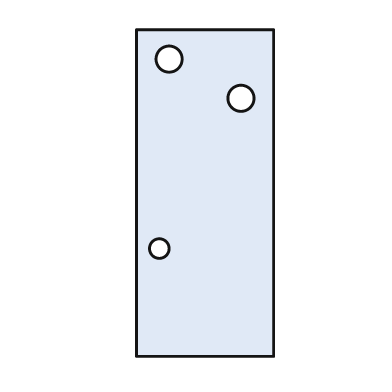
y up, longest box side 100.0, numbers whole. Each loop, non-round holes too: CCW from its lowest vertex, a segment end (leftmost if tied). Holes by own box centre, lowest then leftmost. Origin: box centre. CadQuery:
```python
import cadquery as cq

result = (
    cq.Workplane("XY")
    .moveTo(-21.0, -50.0)
    .lineTo(21.0, -50.0)
    .lineTo(21.0, 50.0)
    .lineTo(-21.0, 50.0)
    .close()
    .moveTo(-14.0, -17.0)
    .circle(3.0)
    .moveTo(11.0, 29.0)
    .circle(4.0)
    .moveTo(-11.0, 41.0)
    .circle(4.0)
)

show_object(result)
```